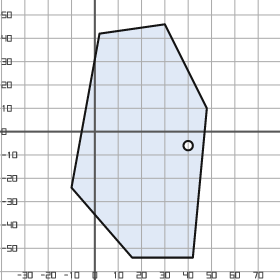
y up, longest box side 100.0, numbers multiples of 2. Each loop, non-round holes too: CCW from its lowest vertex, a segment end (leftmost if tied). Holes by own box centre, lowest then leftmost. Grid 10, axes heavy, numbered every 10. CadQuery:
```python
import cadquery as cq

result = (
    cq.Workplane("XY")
    .moveTo(16.0, -54.0)
    .lineTo(42.0, -54.0)
    .lineTo(48.0, 10.0)
    .lineTo(30.0, 46.0)
    .lineTo(2.0, 42.0)
    .lineTo(-10.0, -24.0)
    .close()
    .moveTo(40.0, -6.0)
    .circle(2.0)
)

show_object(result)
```